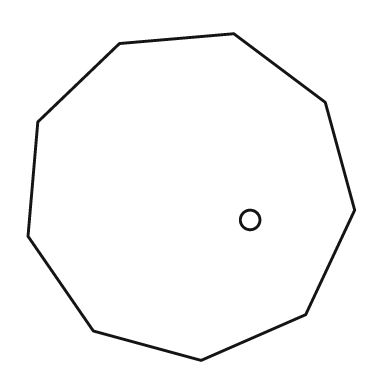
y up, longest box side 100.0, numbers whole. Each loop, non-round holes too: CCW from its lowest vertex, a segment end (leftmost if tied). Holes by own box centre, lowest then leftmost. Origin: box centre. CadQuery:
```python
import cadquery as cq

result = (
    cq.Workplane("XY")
    .moveTo(3.0, -50.0)
    .lineTo(35.0, -36.0)
    .lineTo(50.0, -4.0)
    .lineTo(41.0, 29.0)
    .lineTo(13.0, 50.0)
    .lineTo(-22.0, 47.0)
    .lineTo(-47.0, 23.0)
    .lineTo(-50.0, -12.0)
    .lineTo(-30.0, -41.0)
    .close()
    .moveTo(18.0, -7.0)
    .circle(3.0)
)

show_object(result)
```